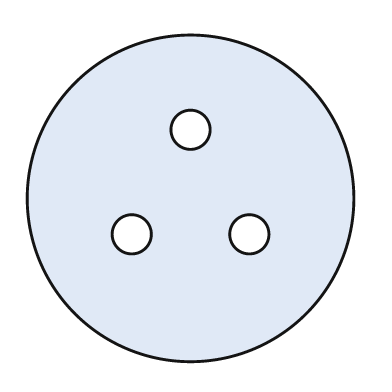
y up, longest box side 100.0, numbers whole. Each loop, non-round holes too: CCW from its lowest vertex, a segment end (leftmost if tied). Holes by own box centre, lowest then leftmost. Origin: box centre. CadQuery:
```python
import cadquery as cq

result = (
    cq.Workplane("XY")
    .moveTo(0.0, 0.0)
    .circle(50.0)
    .moveTo(-18.0, -11.0)
    .circle(6.0)
    .moveTo(18.0, -11.0)
    .circle(6.0)
    .moveTo(0.0, 21.0)
    .circle(6.0)
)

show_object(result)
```